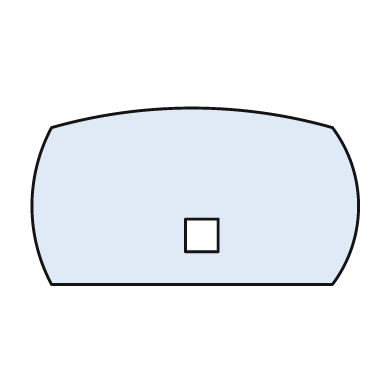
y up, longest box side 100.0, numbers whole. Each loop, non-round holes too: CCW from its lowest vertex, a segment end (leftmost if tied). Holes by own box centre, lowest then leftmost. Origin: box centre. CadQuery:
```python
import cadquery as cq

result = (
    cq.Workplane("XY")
    .moveTo(-44.0, -27.0)
    .lineTo(42.0, -27.0)
    .threePointArc((50.0, -3.0), (42.0, 21.0))
    .threePointArc((-1.0, 27.0), (-44.0, 21.0))
    .threePointArc((-50.0, -3.0), (-44.0, -27.0))
    .close()
    .moveTo(-3.0, -17.0)
    .lineTo(7.0, -17.0)
    .lineTo(7.0, -7.0)
    .lineTo(-3.0, -7.0)
    .close()
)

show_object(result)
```